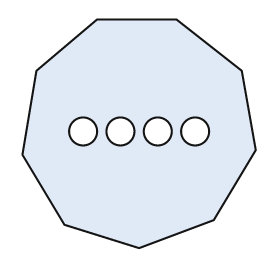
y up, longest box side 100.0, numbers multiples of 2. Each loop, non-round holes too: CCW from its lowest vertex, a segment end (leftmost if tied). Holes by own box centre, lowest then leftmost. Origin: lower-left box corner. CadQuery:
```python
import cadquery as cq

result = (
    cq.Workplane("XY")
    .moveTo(50.0, 0.0)
    .lineTo(82.0, 12.0)
    .lineTo(100.0, 42.0)
    .lineTo(94.0, 76.0)
    .lineTo(66.0, 98.0)
    .lineTo(32.0, 98.0)
    .lineTo(6.0, 76.0)
    .lineTo(0.0, 40.0)
    .lineTo(18.0, 10.0)
    .close()
    .moveTo(26.0, 50.0)
    .circle(6.0)
    .moveTo(42.0, 50.0)
    .circle(6.0)
    .moveTo(58.0, 50.0)
    .circle(6.0)
    .moveTo(74.0, 50.0)
    .circle(6.0)
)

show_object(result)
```